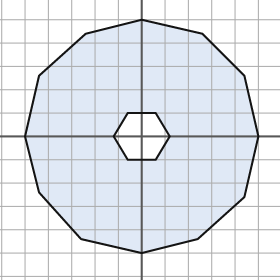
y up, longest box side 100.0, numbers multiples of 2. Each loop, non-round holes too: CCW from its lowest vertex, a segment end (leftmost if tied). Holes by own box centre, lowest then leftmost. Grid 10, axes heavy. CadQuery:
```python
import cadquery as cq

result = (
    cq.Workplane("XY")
    .moveTo(0.0, -50.0)
    .lineTo(24.0, -44.0)
    .lineTo(44.0, -26.0)
    .lineTo(50.0, 0.0)
    .lineTo(44.0, 26.0)
    .lineTo(26.0, 44.0)
    .lineTo(0.0, 50.0)
    .lineTo(-24.0, 44.0)
    .lineTo(-44.0, 26.0)
    .lineTo(-50.0, 0.0)
    .lineTo(-44.0, -24.0)
    .lineTo(-26.0, -44.0)
    .close()
    .moveTo(-6.0, -10.0)
    .lineTo(6.0, -10.0)
    .lineTo(12.0, 0.0)
    .lineTo(6.0, 10.0)
    .lineTo(-6.0, 10.0)
    .lineTo(-12.0, 0.0)
    .close()
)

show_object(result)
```